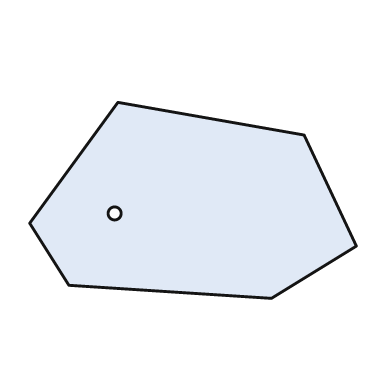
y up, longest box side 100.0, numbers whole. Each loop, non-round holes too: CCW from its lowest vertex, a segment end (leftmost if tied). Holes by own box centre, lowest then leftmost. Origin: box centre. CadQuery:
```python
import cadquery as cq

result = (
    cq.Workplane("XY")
    .moveTo(24.0, -30.0)
    .lineTo(50.0, -14.0)
    .lineTo(34.0, 20.0)
    .lineTo(-23.0, 30.0)
    .lineTo(-50.0, -7.0)
    .lineTo(-38.0, -26.0)
    .close()
    .moveTo(-24.0, -4.0)
    .circle(2.0)
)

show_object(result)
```